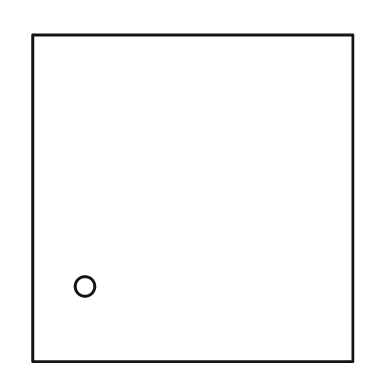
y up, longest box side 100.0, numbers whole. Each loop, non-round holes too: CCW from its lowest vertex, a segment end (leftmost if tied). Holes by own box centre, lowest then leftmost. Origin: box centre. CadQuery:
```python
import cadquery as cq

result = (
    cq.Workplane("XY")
    .moveTo(-49.0, -50.0)
    .lineTo(49.0, -50.0)
    .lineTo(49.0, 50.0)
    .lineTo(-49.0, 50.0)
    .close()
    .moveTo(-33.0, -27.0)
    .circle(3.0)
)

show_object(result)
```